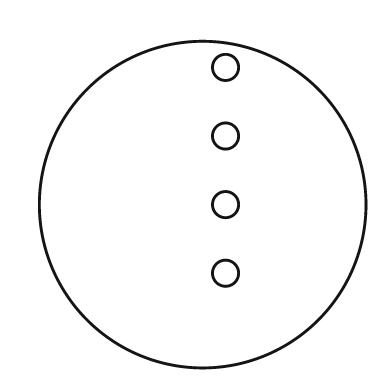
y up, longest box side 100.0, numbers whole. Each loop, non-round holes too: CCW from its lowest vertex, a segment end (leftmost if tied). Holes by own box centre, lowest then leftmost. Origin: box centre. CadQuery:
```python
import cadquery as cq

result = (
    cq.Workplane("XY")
    .moveTo(0.0, 0.0)
    .circle(50.0)
    .moveTo(7.0, -21.0)
    .circle(4.0)
    .moveTo(7.0, 0.0)
    .circle(4.0)
    .moveTo(7.0, 21.0)
    .circle(4.0)
    .moveTo(7.0, 42.0)
    .circle(4.0)
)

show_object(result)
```